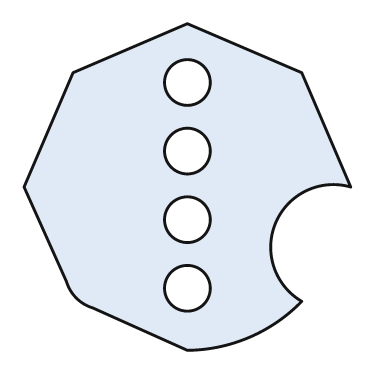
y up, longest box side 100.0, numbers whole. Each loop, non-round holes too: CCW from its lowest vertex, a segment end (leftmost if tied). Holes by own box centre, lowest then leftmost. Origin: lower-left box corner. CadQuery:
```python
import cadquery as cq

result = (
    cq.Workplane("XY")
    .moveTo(50.0, 0.0)
    .threePointArc((69.0, 4.0), (85.0, 15.0))
    .threePointArc((77.0, 39.0), (100.0, 50.0))
    .lineTo(85.0, 85.0)
    .lineTo(50.0, 100.0)
    .lineTo(15.0, 85.0)
    .lineTo(0.0, 50.0)
    .lineTo(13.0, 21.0)
    .threePointArc((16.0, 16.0), (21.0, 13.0))
    .close()
    .moveTo(50.0, 19.0)
    .circle(7.0)
    .moveTo(50.0, 40.0)
    .circle(7.0)
    .moveTo(50.0, 61.0)
    .circle(7.0)
    .moveTo(50.0, 82.0)
    .circle(7.0)
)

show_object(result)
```